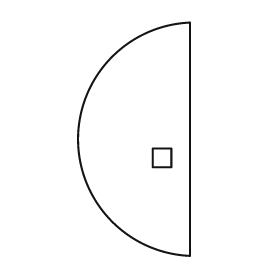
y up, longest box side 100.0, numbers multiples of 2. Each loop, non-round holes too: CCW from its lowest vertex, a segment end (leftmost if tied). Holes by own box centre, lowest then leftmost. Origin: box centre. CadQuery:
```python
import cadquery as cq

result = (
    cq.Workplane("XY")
    .moveTo(24.0, -50.0)
    .lineTo(24.0, 50.0)
    .threePointArc((-24.0, 0.0), (24.0, -50.0))
    .close()
    .moveTo(8.0, -12.0)
    .lineTo(16.0, -12.0)
    .lineTo(16.0, -4.0)
    .lineTo(8.0, -4.0)
    .close()
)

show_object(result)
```